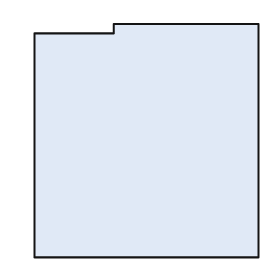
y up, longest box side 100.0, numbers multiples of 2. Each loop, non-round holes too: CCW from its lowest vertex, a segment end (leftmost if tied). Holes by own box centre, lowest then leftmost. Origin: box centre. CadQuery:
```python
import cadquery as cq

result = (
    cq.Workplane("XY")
    .moveTo(-48.0, -50.0)
    .lineTo(48.0, -50.0)
    .lineTo(48.0, 50.0)
    .lineTo(-14.0, 50.0)
    .lineTo(-14.0, 46.0)
    .lineTo(-48.0, 46.0)
    .close()
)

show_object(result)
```